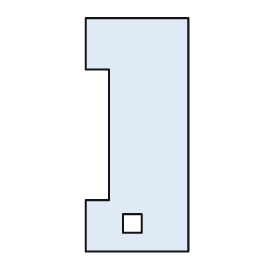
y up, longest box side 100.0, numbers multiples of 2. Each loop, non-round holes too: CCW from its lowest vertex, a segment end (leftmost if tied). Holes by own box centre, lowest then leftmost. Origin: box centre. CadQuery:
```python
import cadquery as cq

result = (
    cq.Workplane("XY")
    .moveTo(-22.0, -50.0)
    .lineTo(22.0, -50.0)
    .lineTo(22.0, 50.0)
    .lineTo(-22.0, 50.0)
    .lineTo(-22.0, 28.0)
    .lineTo(-12.0, 28.0)
    .lineTo(-12.0, -28.0)
    .lineTo(-22.0, -28.0)
    .close()
    .moveTo(-6.0, -42.0)
    .lineTo(2.0, -42.0)
    .lineTo(2.0, -34.0)
    .lineTo(-6.0, -34.0)
    .close()
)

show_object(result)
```